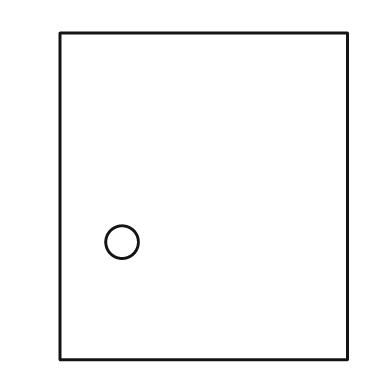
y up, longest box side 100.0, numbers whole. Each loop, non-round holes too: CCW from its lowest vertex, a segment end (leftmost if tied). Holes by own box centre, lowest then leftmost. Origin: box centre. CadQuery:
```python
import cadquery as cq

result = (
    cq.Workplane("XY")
    .moveTo(-44.0, -50.0)
    .lineTo(44.0, -50.0)
    .lineTo(44.0, 50.0)
    .lineTo(-44.0, 50.0)
    .close()
    .moveTo(-25.0, -14.0)
    .circle(5.0)
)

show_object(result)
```